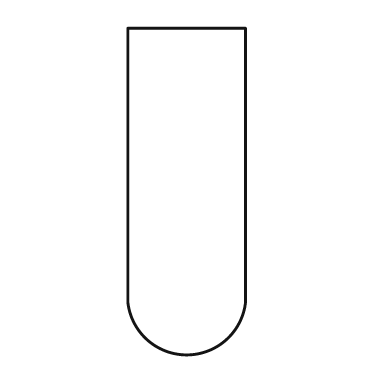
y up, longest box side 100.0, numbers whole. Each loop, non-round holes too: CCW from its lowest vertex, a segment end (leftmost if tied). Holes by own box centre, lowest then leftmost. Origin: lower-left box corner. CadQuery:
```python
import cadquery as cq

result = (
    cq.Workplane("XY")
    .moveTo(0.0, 16.0)
    .threePointArc((18.0, 0.0), (36.0, 16.0))
    .lineTo(36.0, 100.0)
    .lineTo(0.0, 100.0)
    .close()
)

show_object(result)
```